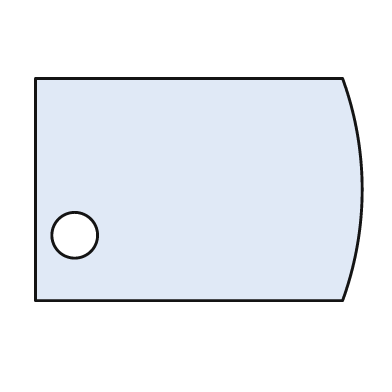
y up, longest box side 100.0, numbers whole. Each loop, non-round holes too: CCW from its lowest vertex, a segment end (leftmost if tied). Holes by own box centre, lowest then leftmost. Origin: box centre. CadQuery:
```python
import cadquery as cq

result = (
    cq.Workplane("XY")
    .moveTo(-50.0, -34.0)
    .lineTo(44.0, -34.0)
    .threePointArc((50.0, 0.0), (44.0, 34.0))
    .lineTo(-50.0, 34.0)
    .close()
    .moveTo(-38.0, -14.0)
    .circle(7.0)
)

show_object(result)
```